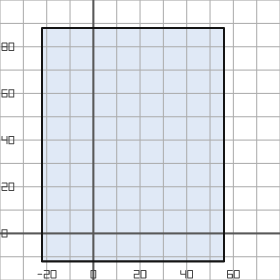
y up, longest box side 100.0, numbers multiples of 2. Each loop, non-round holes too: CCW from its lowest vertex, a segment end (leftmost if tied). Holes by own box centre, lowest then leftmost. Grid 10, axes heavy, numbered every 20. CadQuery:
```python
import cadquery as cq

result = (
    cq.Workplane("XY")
    .moveTo(-22.0, -12.0)
    .lineTo(56.0, -12.0)
    .lineTo(56.0, 88.0)
    .lineTo(-22.0, 88.0)
    .close()
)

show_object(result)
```